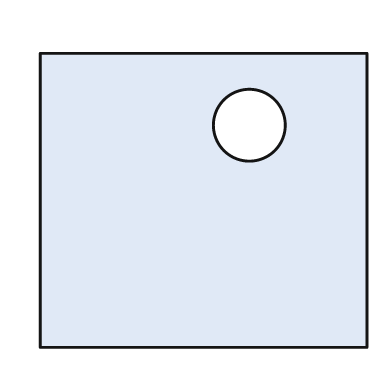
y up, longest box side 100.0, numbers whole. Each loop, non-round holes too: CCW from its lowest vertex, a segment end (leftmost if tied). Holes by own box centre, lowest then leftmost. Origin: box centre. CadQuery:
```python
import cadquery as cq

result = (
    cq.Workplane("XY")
    .moveTo(-50.0, -45.0)
    .lineTo(50.0, -45.0)
    .lineTo(50.0, 45.0)
    .lineTo(-50.0, 45.0)
    .close()
    .moveTo(14.0, 23.0)
    .circle(11.0)
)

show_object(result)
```